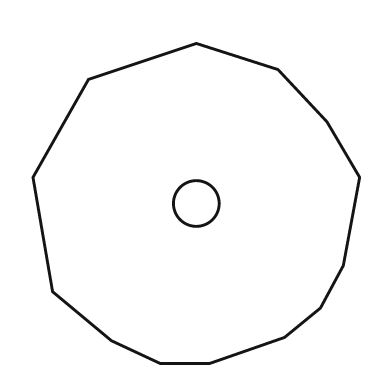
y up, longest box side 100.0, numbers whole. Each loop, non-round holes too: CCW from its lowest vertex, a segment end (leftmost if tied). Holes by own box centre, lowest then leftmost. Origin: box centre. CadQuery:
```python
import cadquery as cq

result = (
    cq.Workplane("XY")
    .moveTo(-11.0, -49.0)
    .lineTo(4.0, -49.0)
    .lineTo(27.0, -41.0)
    .lineTo(38.0, -32.0)
    .lineTo(45.0, -19.0)
    .lineTo(50.0, 8.0)
    .lineTo(40.0, 25.0)
    .lineTo(25.0, 41.0)
    .lineTo(0.0, 49.0)
    .lineTo(-33.0, 38.0)
    .lineTo(-50.0, 8.0)
    .lineTo(-44.0, -27.0)
    .lineTo(-26.0, -42.0)
    .close()
    .moveTo(0.0, 0.0)
    .circle(7.0)
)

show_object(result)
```